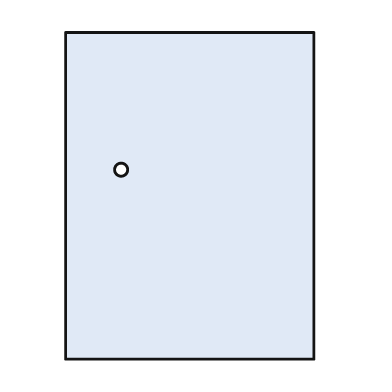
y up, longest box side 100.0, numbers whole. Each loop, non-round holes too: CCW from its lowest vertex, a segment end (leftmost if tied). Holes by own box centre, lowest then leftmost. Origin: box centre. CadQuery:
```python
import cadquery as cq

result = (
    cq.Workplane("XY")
    .moveTo(-38.0, -50.0)
    .lineTo(38.0, -50.0)
    .lineTo(38.0, 50.0)
    .lineTo(-38.0, 50.0)
    .close()
    .moveTo(-21.0, 8.0)
    .circle(2.0)
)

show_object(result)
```